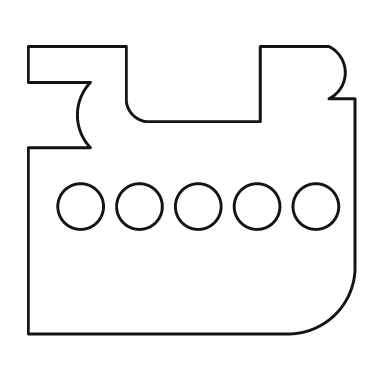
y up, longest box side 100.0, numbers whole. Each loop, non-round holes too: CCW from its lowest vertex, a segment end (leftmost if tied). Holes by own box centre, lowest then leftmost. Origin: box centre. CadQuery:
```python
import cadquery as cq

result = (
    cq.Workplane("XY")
    .moveTo(-50.0, -44.0)
    .lineTo(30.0, -44.0)
    .threePointArc((44.0, -38.0), (50.0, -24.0))
    .lineTo(50.0, 28.0)
    .lineTo(42.0, 28.0)
    .threePointArc((47.0, 36.0), (42.0, 44.0))
    .lineTo(21.0, 44.0)
    .lineTo(21.0, 21.0)
    .lineTo(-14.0, 21.0)
    .threePointArc((-18.0, 23.0), (-20.0, 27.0))
    .lineTo(-20.0, 44.0)
    .lineTo(-50.0, 44.0)
    .lineTo(-50.0, 33.0)
    .lineTo(-31.0, 33.0)
    .threePointArc((-35.0, 23.0), (-31.0, 13.0))
    .lineTo(-50.0, 13.0)
    .close()
    .moveTo(-34.0, -5.0)
    .circle(7.0)
    .moveTo(-16.0, -5.0)
    .circle(7.0)
    .moveTo(2.0, -5.0)
    .circle(7.0)
    .moveTo(20.0, -5.0)
    .circle(7.0)
    .moveTo(38.0, -5.0)
    .circle(7.0)
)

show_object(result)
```